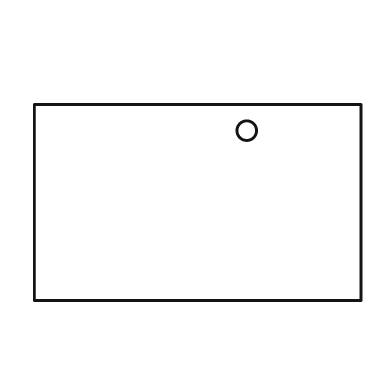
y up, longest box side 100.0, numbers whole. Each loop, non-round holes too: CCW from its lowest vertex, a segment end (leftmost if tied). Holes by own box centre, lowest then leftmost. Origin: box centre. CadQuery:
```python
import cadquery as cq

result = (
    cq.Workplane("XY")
    .moveTo(-50.0, -30.0)
    .lineTo(50.0, -30.0)
    .lineTo(50.0, 30.0)
    .lineTo(-50.0, 30.0)
    .close()
    .moveTo(15.0, 22.0)
    .circle(3.0)
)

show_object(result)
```